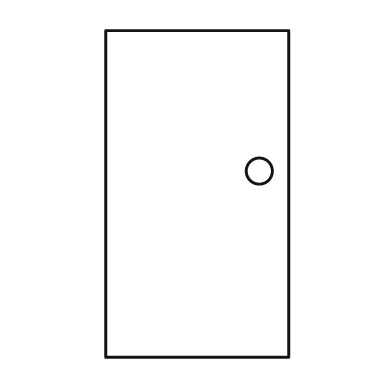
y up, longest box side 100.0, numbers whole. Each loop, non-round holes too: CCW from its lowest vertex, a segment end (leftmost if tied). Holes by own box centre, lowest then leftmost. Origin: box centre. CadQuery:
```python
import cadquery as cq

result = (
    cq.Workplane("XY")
    .moveTo(-28.0, -50.0)
    .lineTo(28.0, -50.0)
    .lineTo(28.0, 50.0)
    .lineTo(-28.0, 50.0)
    .close()
    .moveTo(19.0, 7.0)
    .circle(4.0)
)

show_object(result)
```